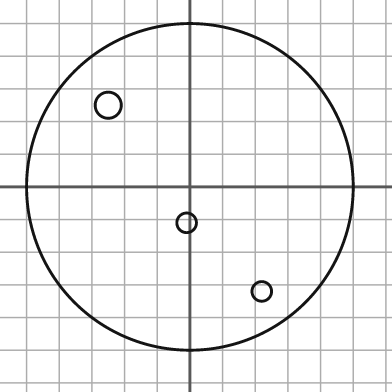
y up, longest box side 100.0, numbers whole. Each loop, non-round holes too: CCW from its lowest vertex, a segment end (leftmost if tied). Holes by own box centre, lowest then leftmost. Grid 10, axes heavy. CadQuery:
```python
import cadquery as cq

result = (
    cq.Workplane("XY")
    .moveTo(0.0, 0.0)
    .circle(50.0)
    .moveTo(22.0, -32.0)
    .circle(3.0)
    .moveTo(-1.0, -11.0)
    .circle(3.0)
    .moveTo(-25.0, 25.0)
    .circle(4.0)
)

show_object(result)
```